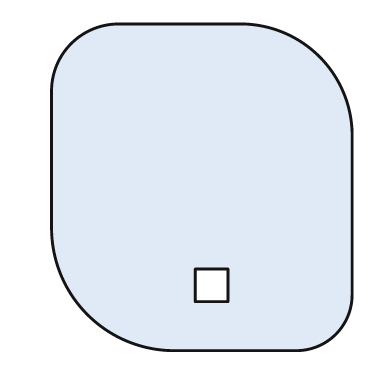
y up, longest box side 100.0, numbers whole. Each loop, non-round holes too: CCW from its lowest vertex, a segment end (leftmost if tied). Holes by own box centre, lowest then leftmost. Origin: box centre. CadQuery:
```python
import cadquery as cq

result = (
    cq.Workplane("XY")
    .moveTo(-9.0, -50.0)
    .lineTo(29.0, -50.0)
    .threePointArc((41.0, -45.0), (46.0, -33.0))
    .lineTo(46.0, 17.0)
    .threePointArc((36.0, 40.0), (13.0, 50.0))
    .lineTo(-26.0, 50.0)
    .threePointArc((-40.0, 44.0), (-46.0, 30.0))
    .lineTo(-46.0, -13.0)
    .threePointArc((-35.0, -39.0), (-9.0, -50.0))
    .close()
    .moveTo(-2.0, -35.0)
    .lineTo(8.0, -35.0)
    .lineTo(8.0, -25.0)
    .lineTo(-2.0, -25.0)
    .close()
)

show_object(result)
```